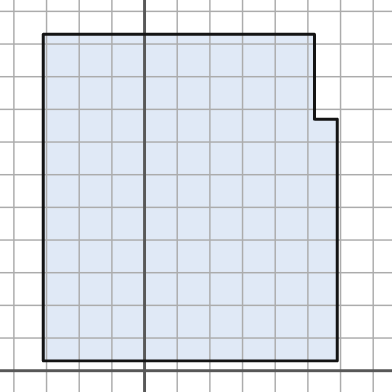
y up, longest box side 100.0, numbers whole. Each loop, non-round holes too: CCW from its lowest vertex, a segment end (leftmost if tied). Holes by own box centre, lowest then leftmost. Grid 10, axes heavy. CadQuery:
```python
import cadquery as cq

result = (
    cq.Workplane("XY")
    .moveTo(-31.0, 3.0)
    .lineTo(59.0, 3.0)
    .lineTo(59.0, 77.0)
    .lineTo(52.0, 77.0)
    .lineTo(52.0, 103.0)
    .lineTo(-31.0, 103.0)
    .close()
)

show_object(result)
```